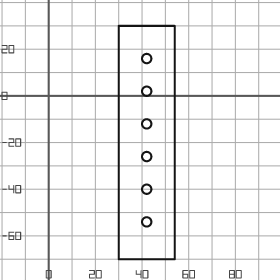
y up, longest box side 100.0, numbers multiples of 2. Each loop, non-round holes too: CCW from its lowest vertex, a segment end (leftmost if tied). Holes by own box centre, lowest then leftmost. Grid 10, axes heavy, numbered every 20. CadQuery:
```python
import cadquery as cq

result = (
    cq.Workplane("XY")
    .moveTo(30.0, -70.0)
    .lineTo(54.0, -70.0)
    .lineTo(54.0, 30.0)
    .lineTo(30.0, 30.0)
    .close()
    .moveTo(42.0, -54.0)
    .circle(2.0)
    .moveTo(42.0, -40.0)
    .circle(2.0)
    .moveTo(42.0, -26.0)
    .circle(2.0)
    .moveTo(42.0, -12.0)
    .circle(2.0)
    .moveTo(42.0, 2.0)
    .circle(2.0)
    .moveTo(42.0, 16.0)
    .circle(2.0)
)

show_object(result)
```